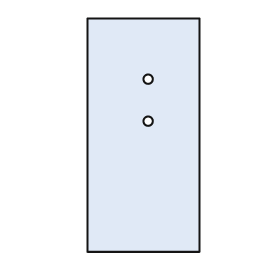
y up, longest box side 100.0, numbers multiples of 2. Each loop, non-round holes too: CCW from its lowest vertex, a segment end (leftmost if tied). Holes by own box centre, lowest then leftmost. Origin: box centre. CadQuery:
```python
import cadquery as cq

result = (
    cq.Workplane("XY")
    .moveTo(-24.0, -50.0)
    .lineTo(24.0, -50.0)
    .lineTo(24.0, 50.0)
    .lineTo(-24.0, 50.0)
    .close()
    .moveTo(2.0, 6.0)
    .circle(2.0)
    .moveTo(2.0, 24.0)
    .circle(2.0)
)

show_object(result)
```